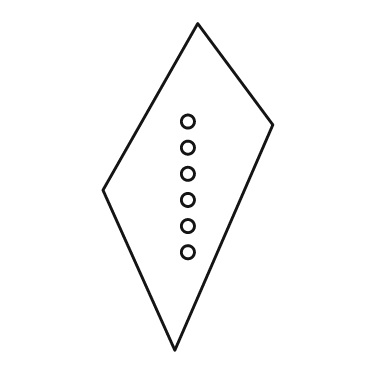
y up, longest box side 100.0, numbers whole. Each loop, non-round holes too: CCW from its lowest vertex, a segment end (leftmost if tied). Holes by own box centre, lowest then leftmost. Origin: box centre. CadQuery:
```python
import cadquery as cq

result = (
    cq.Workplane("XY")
    .moveTo(-4.0, -50.0)
    .lineTo(26.0, 19.0)
    .lineTo(3.0, 50.0)
    .lineTo(-26.0, -1.0)
    .close()
    .moveTo(0.0, -20.0)
    .circle(2.0)
    .moveTo(0.0, -12.0)
    .circle(2.0)
    .moveTo(0.0, -4.0)
    .circle(2.0)
    .moveTo(0.0, 4.0)
    .circle(2.0)
    .moveTo(0.0, 12.0)
    .circle(2.0)
    .moveTo(0.0, 20.0)
    .circle(2.0)
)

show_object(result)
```